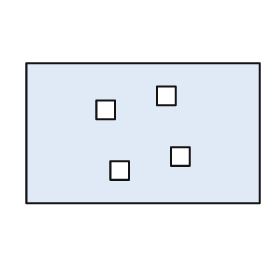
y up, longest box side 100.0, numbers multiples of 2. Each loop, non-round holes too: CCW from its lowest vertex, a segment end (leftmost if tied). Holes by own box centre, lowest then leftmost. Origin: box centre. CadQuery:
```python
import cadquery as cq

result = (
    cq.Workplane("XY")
    .moveTo(-50.0, -30.0)
    .lineTo(50.0, -30.0)
    .lineTo(50.0, 30.0)
    .lineTo(-50.0, 30.0)
    .close()
    .moveTo(-14.0, -20.0)
    .lineTo(-6.0, -20.0)
    .lineTo(-6.0, -12.0)
    .lineTo(-14.0, -12.0)
    .close()
    .moveTo(12.0, -14.0)
    .lineTo(20.0, -14.0)
    .lineTo(20.0, -6.0)
    .lineTo(12.0, -6.0)
    .close()
    .moveTo(-20.0, 6.0)
    .lineTo(-12.0, 6.0)
    .lineTo(-12.0, 14.0)
    .lineTo(-20.0, 14.0)
    .close()
    .moveTo(6.0, 12.0)
    .lineTo(14.0, 12.0)
    .lineTo(14.0, 20.0)
    .lineTo(6.0, 20.0)
    .close()
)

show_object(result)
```